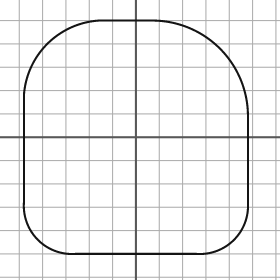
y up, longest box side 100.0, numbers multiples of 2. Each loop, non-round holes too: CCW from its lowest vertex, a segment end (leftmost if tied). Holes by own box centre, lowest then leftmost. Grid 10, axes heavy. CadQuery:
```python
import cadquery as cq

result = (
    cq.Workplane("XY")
    .moveTo(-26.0, -50.0)
    .lineTo(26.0, -50.0)
    .threePointArc((42.0, -44.0), (48.0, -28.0))
    .lineTo(48.0, 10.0)
    .threePointArc((36.0, 38.0), (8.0, 50.0))
    .lineTo(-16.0, 50.0)
    .threePointArc((-38.0, 40.0), (-48.0, 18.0))
    .lineTo(-48.0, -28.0)
    .threePointArc((-42.0, -44.0), (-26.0, -50.0))
    .close()
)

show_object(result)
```